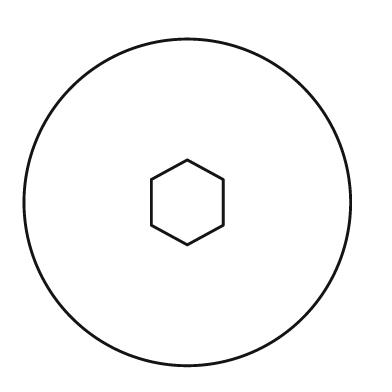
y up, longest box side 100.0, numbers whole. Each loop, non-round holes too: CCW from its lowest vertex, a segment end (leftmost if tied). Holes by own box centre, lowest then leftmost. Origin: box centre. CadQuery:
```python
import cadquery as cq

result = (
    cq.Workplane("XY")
    .moveTo(0.0, 0.0)
    .circle(50.0)
    .moveTo(0.0, -13.0)
    .lineTo(11.0, -7.0)
    .lineTo(11.0, 7.0)
    .lineTo(0.0, 13.0)
    .lineTo(-11.0, 7.0)
    .lineTo(-11.0, -7.0)
    .close()
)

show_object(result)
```